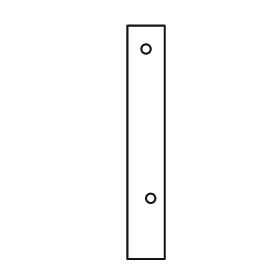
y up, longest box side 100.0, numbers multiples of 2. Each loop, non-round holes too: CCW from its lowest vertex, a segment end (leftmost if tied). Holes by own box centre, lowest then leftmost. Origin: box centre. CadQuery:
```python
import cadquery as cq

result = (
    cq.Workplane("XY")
    .moveTo(-8.0, -50.0)
    .lineTo(8.0, -50.0)
    .lineTo(8.0, 50.0)
    .lineTo(-8.0, 50.0)
    .close()
    .moveTo(2.0, -24.0)
    .circle(2.0)
    .moveTo(0.0, 40.0)
    .circle(2.0)
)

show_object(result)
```